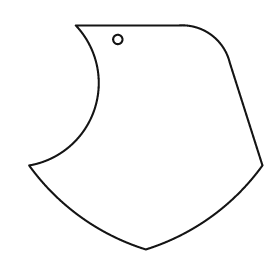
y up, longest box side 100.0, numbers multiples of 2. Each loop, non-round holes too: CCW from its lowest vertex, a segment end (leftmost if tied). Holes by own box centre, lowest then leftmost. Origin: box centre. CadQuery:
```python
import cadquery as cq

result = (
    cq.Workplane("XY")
    .moveTo(0.0, -48.0)
    .threePointArc((28.0, -34.0), (50.0, -12.0))
    .lineTo(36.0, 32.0)
    .threePointArc((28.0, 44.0), (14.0, 48.0))
    .lineTo(-30.0, 48.0)
    .threePointArc((-22.0, 12.0), (-50.0, -12.0))
    .threePointArc((-28.0, -34.0), (0.0, -48.0))
    .close()
    .moveTo(-12.0, 42.0)
    .circle(2.0)
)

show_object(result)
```